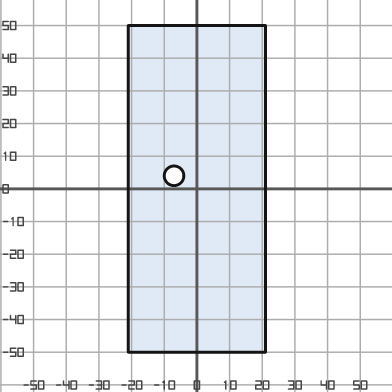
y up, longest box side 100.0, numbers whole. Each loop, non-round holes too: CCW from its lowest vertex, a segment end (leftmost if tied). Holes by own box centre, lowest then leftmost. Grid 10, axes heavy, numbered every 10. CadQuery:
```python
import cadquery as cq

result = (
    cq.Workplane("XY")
    .moveTo(-21.0, -50.0)
    .lineTo(21.0, -50.0)
    .lineTo(21.0, 50.0)
    .lineTo(-21.0, 50.0)
    .close()
    .moveTo(-7.0, 4.0)
    .circle(3.0)
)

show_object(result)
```